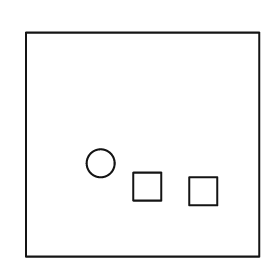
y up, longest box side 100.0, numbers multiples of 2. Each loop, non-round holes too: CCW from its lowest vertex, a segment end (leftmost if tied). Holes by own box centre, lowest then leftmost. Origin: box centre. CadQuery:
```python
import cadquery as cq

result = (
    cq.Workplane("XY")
    .moveTo(-50.0, -48.0)
    .lineTo(50.0, -48.0)
    .lineTo(50.0, 48.0)
    .lineTo(-50.0, 48.0)
    .close()
    .moveTo(20.0, -26.0)
    .lineTo(32.0, -26.0)
    .lineTo(32.0, -14.0)
    .lineTo(20.0, -14.0)
    .close()
    .moveTo(-4.0, -24.0)
    .lineTo(8.0, -24.0)
    .lineTo(8.0, -12.0)
    .lineTo(-4.0, -12.0)
    .close()
    .moveTo(-18.0, -8.0)
    .circle(6.0)
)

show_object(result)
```